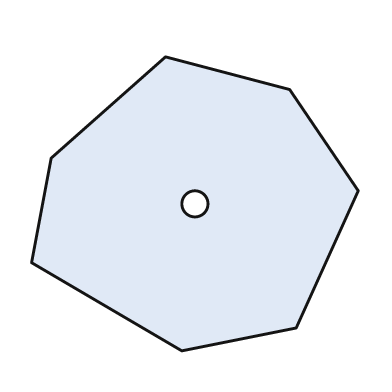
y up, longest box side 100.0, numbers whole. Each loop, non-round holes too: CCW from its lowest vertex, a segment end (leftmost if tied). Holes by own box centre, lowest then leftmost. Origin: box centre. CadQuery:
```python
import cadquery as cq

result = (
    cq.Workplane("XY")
    .moveTo(-4.0, -45.0)
    .lineTo(31.0, -38.0)
    .lineTo(50.0, 4.0)
    .lineTo(29.0, 35.0)
    .lineTo(-9.0, 45.0)
    .lineTo(-44.0, 14.0)
    .lineTo(-50.0, -18.0)
    .close()
    .moveTo(0.0, 0.0)
    .circle(4.0)
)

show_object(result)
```